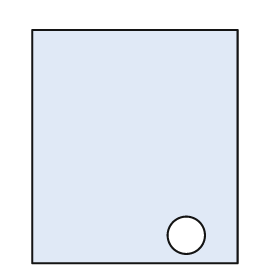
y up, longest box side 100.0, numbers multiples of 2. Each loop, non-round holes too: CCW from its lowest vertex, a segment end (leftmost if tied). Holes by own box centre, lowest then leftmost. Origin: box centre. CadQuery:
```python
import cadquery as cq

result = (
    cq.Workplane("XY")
    .moveTo(-44.0, -50.0)
    .lineTo(44.0, -50.0)
    .lineTo(44.0, 50.0)
    .lineTo(-44.0, 50.0)
    .close()
    .moveTo(22.0, -38.0)
    .circle(8.0)
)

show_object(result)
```